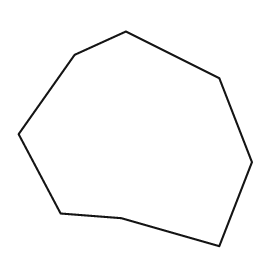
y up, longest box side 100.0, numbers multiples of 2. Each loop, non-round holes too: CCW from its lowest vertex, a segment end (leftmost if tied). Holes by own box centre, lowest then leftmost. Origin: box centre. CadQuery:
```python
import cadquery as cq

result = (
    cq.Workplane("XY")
    .moveTo(36.0, -46.0)
    .lineTo(50.0, -10.0)
    .lineTo(36.0, 26.0)
    .lineTo(-4.0, 46.0)
    .lineTo(-26.0, 36.0)
    .lineTo(-50.0, 2.0)
    .lineTo(-32.0, -32.0)
    .lineTo(-6.0, -34.0)
    .close()
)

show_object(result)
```